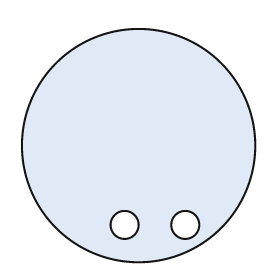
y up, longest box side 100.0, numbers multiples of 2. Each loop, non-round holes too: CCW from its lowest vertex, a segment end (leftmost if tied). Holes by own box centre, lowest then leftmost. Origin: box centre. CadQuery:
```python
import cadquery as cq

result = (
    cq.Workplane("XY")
    .moveTo(0.0, 0.0)
    .circle(50.0)
    .moveTo(-6.0, -34.0)
    .circle(6.0)
    .moveTo(20.0, -34.0)
    .circle(6.0)
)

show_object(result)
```